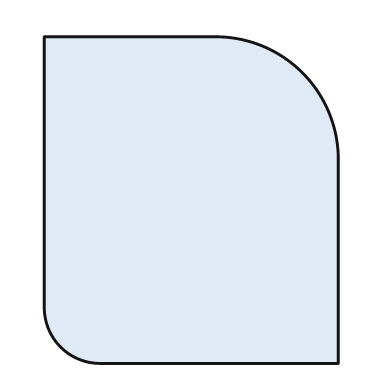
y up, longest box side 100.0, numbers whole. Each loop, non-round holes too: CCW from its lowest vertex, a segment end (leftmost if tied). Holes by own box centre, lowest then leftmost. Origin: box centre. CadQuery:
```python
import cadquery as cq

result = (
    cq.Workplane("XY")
    .moveTo(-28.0, -50.0)
    .lineTo(45.0, -50.0)
    .lineTo(45.0, 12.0)
    .threePointArc((34.0, 39.0), (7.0, 50.0))
    .lineTo(-45.0, 50.0)
    .lineTo(-45.0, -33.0)
    .threePointArc((-40.0, -45.0), (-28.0, -50.0))
    .close()
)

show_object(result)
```